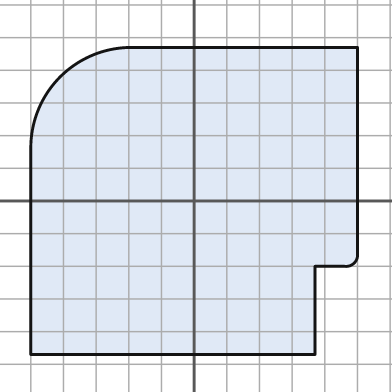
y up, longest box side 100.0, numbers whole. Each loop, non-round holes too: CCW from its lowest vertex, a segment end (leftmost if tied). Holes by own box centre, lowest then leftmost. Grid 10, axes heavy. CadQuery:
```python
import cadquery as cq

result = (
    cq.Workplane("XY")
    .moveTo(-50.0, -47.0)
    .lineTo(37.0, -47.0)
    .lineTo(37.0, -20.0)
    .lineTo(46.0, -20.0)
    .threePointArc((49.0, -19.0), (50.0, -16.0))
    .lineTo(50.0, 47.0)
    .lineTo(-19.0, 47.0)
    .threePointArc((-41.0, 38.0), (-50.0, 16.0))
    .close()
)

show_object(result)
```